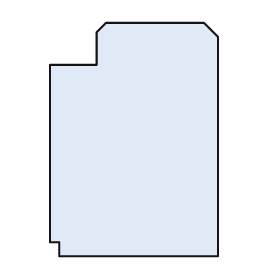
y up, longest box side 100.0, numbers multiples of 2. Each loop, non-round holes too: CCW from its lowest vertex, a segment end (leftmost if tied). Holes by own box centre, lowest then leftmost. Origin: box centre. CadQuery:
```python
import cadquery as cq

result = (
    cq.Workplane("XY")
    .moveTo(-32.0, -50.0)
    .lineTo(36.0, -50.0)
    .lineTo(36.0, 44.0)
    .lineTo(30.0, 50.0)
    .lineTo(-12.0, 50.0)
    .lineTo(-16.0, 46.0)
    .lineTo(-16.0, 32.0)
    .lineTo(-36.0, 32.0)
    .lineTo(-36.0, -44.0)
    .lineTo(-32.0, -44.0)
    .close()
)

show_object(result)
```